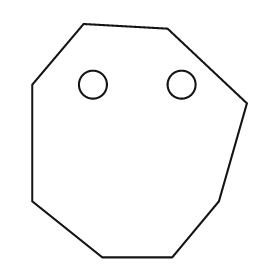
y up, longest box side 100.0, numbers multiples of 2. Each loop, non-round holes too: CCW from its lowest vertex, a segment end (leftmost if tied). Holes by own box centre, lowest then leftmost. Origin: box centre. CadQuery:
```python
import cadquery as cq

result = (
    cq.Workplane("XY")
    .moveTo(-16.0, -50.0)
    .lineTo(14.0, -50.0)
    .lineTo(34.0, -26.0)
    .lineTo(46.0, 16.0)
    .lineTo(12.0, 48.0)
    .lineTo(-24.0, 50.0)
    .lineTo(-46.0, 24.0)
    .lineTo(-46.0, -26.0)
    .close()
    .moveTo(-20.0, 24.0)
    .circle(6.0)
    .moveTo(18.0, 24.0)
    .circle(6.0)
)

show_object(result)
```